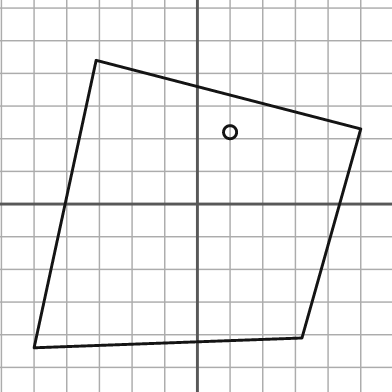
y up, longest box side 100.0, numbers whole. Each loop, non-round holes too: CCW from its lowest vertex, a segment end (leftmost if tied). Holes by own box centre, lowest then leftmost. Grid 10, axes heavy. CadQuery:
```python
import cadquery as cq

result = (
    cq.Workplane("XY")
    .moveTo(-50.0, -44.0)
    .lineTo(32.0, -41.0)
    .lineTo(50.0, 23.0)
    .lineTo(-31.0, 44.0)
    .close()
    .moveTo(10.0, 22.0)
    .circle(2.0)
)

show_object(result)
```